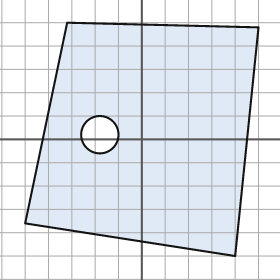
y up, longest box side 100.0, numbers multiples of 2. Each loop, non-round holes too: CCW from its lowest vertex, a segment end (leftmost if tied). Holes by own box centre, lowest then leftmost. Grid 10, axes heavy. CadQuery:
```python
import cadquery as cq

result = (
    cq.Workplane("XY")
    .moveTo(40.0, -50.0)
    .lineTo(50.0, 48.0)
    .lineTo(-32.0, 50.0)
    .lineTo(-50.0, -36.0)
    .close()
    .moveTo(-18.0, 2.0)
    .circle(8.0)
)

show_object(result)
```